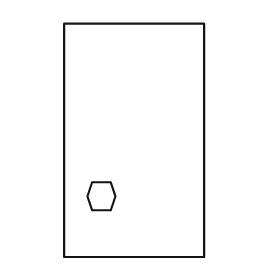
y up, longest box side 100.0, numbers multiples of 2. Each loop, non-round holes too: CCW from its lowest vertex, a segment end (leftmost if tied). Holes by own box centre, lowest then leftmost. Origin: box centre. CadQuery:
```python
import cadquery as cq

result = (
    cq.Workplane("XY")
    .moveTo(-30.0, -50.0)
    .lineTo(30.0, -50.0)
    .lineTo(30.0, 50.0)
    .lineTo(-30.0, 50.0)
    .close()
    .moveTo(-18.0, -30.0)
    .lineTo(-10.0, -30.0)
    .lineTo(-8.0, -24.0)
    .lineTo(-10.0, -18.0)
    .lineTo(-18.0, -18.0)
    .lineTo(-20.0, -24.0)
    .close()
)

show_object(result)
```